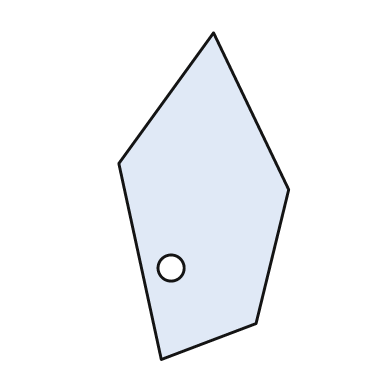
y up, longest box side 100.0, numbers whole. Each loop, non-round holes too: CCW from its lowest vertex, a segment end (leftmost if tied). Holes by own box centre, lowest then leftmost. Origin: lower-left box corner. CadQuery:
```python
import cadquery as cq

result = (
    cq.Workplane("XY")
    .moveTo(13.0, 0.0)
    .lineTo(42.0, 11.0)
    .lineTo(52.0, 52.0)
    .lineTo(29.0, 100.0)
    .lineTo(0.0, 60.0)
    .close()
    .moveTo(16.0, 28.0)
    .circle(4.0)
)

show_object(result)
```